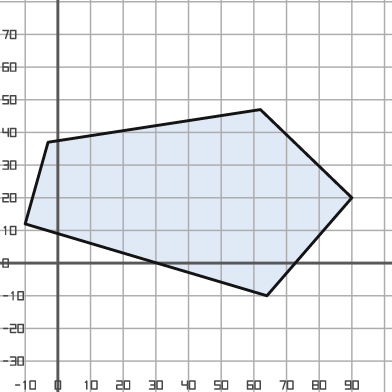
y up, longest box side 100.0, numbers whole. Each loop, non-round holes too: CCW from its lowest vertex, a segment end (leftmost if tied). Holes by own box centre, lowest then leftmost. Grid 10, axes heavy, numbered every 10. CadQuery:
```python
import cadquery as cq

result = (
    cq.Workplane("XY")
    .moveTo(64.0, -10.0)
    .lineTo(90.0, 20.0)
    .lineTo(62.0, 47.0)
    .lineTo(-3.0, 37.0)
    .lineTo(-10.0, 12.0)
    .close()
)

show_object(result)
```